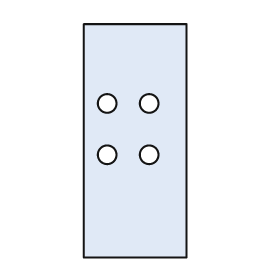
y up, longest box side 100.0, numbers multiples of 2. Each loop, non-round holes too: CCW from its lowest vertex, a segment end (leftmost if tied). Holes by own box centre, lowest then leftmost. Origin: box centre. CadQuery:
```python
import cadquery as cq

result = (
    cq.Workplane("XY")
    .moveTo(-22.0, -50.0)
    .lineTo(22.0, -50.0)
    .lineTo(22.0, 50.0)
    .lineTo(-22.0, 50.0)
    .close()
    .moveTo(-12.0, -6.0)
    .circle(4.0)
    .moveTo(6.0, -6.0)
    .circle(4.0)
    .moveTo(-12.0, 16.0)
    .circle(4.0)
    .moveTo(6.0, 16.0)
    .circle(4.0)
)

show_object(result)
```